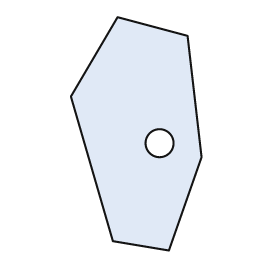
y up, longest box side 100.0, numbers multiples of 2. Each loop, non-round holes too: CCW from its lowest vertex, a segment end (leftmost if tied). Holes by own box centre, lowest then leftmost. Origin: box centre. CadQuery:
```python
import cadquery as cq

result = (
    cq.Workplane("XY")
    .moveTo(14.0, -50.0)
    .lineTo(28.0, -10.0)
    .lineTo(22.0, 42.0)
    .lineTo(-8.0, 50.0)
    .lineTo(-28.0, 16.0)
    .lineTo(-10.0, -46.0)
    .close()
    .moveTo(10.0, -4.0)
    .circle(6.0)
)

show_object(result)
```